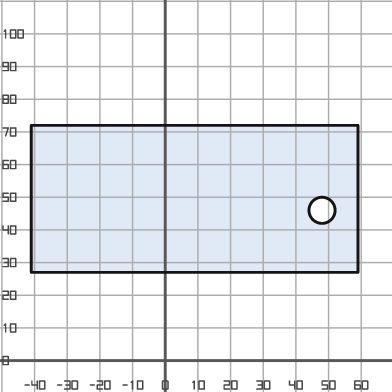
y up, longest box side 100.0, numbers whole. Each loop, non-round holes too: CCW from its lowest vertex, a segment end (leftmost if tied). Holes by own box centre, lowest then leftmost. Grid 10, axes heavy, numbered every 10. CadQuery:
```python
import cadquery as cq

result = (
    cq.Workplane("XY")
    .moveTo(-41.0, 27.0)
    .lineTo(59.0, 27.0)
    .lineTo(59.0, 72.0)
    .lineTo(-41.0, 72.0)
    .close()
    .moveTo(48.0, 46.0)
    .circle(4.0)
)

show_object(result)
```